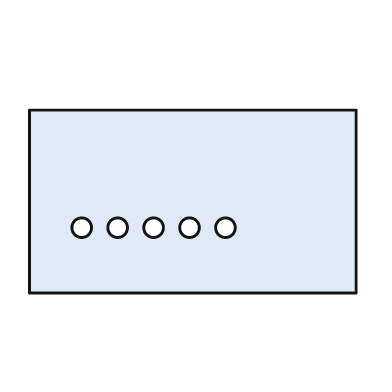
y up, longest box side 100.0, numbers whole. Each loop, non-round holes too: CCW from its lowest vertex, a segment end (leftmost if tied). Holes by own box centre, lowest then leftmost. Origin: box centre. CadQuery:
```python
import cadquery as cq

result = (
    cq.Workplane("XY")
    .moveTo(-50.0, -28.0)
    .lineTo(50.0, -28.0)
    .lineTo(50.0, 28.0)
    .lineTo(-50.0, 28.0)
    .close()
    .moveTo(-34.0, -8.0)
    .circle(3.0)
    .moveTo(-23.0, -8.0)
    .circle(3.0)
    .moveTo(-12.0, -8.0)
    .circle(3.0)
    .moveTo(-1.0, -8.0)
    .circle(3.0)
    .moveTo(10.0, -8.0)
    .circle(3.0)
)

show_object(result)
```